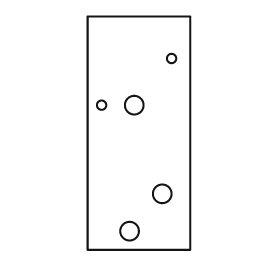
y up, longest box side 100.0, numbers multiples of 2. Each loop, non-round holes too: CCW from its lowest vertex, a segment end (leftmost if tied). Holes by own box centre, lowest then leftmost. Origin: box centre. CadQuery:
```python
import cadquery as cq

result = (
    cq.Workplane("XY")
    .moveTo(-22.0, -50.0)
    .lineTo(22.0, -50.0)
    .lineTo(22.0, 50.0)
    .lineTo(-22.0, 50.0)
    .close()
    .moveTo(-4.0, -42.0)
    .circle(4.0)
    .moveTo(10.0, -26.0)
    .circle(4.0)
    .moveTo(-16.0, 12.0)
    .circle(2.0)
    .moveTo(-2.0, 12.0)
    .circle(4.0)
    .moveTo(14.0, 32.0)
    .circle(2.0)
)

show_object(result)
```